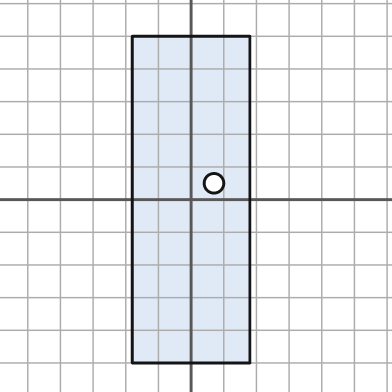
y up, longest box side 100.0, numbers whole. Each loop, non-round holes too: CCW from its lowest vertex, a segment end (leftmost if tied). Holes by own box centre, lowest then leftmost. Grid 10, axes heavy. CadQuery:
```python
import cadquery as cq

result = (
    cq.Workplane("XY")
    .moveTo(-18.0, -50.0)
    .lineTo(18.0, -50.0)
    .lineTo(18.0, 50.0)
    .lineTo(-18.0, 50.0)
    .close()
    .moveTo(7.0, 5.0)
    .circle(3.0)
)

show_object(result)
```